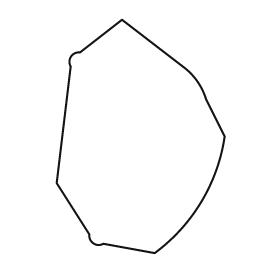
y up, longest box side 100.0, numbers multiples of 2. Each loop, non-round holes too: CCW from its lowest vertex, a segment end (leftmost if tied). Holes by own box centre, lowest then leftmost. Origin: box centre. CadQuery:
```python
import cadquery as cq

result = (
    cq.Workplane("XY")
    .moveTo(6.0, -50.0)
    .threePointArc((26.0, -28.0), (36.0, 0.0))
    .lineTo(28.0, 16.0)
    .threePointArc((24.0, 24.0), (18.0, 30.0))
    .lineTo(-8.0, 50.0)
    .lineTo(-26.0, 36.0)
    .threePointArc((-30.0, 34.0), (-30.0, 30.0))
    .lineTo(-36.0, -20.0)
    .lineTo(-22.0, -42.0)
    .threePointArc((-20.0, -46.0), (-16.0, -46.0))
    .close()
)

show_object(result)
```